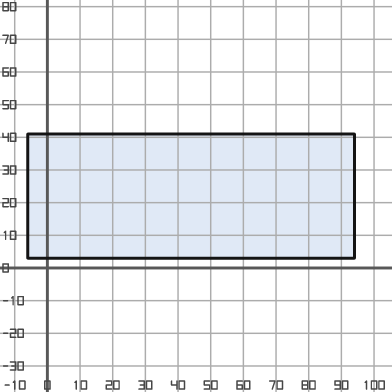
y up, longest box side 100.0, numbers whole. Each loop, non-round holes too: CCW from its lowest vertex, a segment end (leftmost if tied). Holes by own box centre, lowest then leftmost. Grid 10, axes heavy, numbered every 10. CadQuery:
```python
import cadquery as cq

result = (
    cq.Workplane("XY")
    .moveTo(-6.0, 3.0)
    .lineTo(94.0, 3.0)
    .lineTo(94.0, 41.0)
    .lineTo(-6.0, 41.0)
    .close()
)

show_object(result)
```